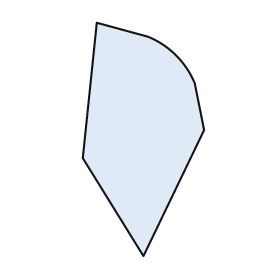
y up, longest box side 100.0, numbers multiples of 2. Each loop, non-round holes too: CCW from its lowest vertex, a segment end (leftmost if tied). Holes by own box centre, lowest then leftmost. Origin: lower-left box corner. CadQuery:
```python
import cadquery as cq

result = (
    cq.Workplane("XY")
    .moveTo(26.0, 0.0)
    .lineTo(52.0, 54.0)
    .lineTo(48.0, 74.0)
    .threePointArc((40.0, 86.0), (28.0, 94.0))
    .lineTo(6.0, 100.0)
    .lineTo(0.0, 42.0)
    .close()
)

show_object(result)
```